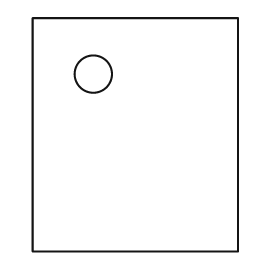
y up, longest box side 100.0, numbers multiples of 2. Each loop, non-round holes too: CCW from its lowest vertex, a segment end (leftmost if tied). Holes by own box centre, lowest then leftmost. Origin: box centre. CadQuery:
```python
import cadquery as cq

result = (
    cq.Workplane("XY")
    .moveTo(-44.0, -50.0)
    .lineTo(44.0, -50.0)
    .lineTo(44.0, 50.0)
    .lineTo(-44.0, 50.0)
    .close()
    .moveTo(-18.0, 26.0)
    .circle(8.0)
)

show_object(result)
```